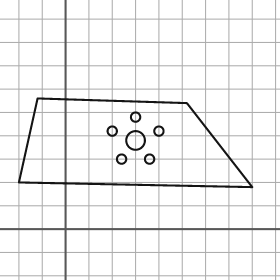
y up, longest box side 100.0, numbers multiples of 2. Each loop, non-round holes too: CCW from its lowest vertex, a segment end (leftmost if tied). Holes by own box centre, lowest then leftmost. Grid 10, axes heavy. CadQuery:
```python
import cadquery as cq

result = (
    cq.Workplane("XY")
    .moveTo(80.0, 18.0)
    .lineTo(52.0, 54.0)
    .lineTo(-12.0, 56.0)
    .lineTo(-20.0, 20.0)
    .close()
    .moveTo(24.0, 30.0)
    .circle(2.0)
    .moveTo(36.0, 30.0)
    .circle(2.0)
    .moveTo(30.0, 38.0)
    .circle(4.0)
    .moveTo(20.0, 42.0)
    .circle(2.0)
    .moveTo(40.0, 42.0)
    .circle(2.0)
    .moveTo(30.0, 48.0)
    .circle(2.0)
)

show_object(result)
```